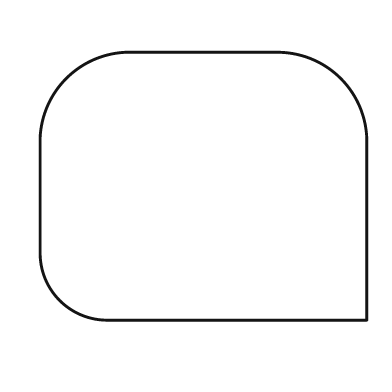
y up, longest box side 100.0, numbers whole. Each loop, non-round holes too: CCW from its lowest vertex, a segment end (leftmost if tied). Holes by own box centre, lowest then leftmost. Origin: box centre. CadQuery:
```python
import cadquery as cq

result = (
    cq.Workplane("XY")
    .moveTo(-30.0, -41.0)
    .lineTo(50.0, -41.0)
    .lineTo(50.0, 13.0)
    .threePointArc((42.0, 33.0), (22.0, 41.0))
    .lineTo(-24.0, 41.0)
    .threePointArc((-42.0, 33.0), (-50.0, 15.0))
    .lineTo(-50.0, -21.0)
    .threePointArc((-44.0, -35.0), (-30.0, -41.0))
    .close()
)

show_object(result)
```